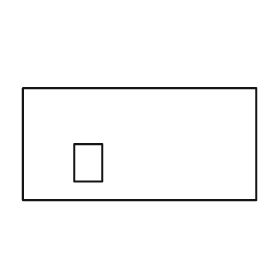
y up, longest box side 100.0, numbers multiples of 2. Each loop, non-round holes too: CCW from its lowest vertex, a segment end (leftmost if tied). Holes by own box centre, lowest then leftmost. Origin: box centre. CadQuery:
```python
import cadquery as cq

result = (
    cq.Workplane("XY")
    .moveTo(-50.0, -24.0)
    .lineTo(50.0, -24.0)
    .lineTo(50.0, 24.0)
    .lineTo(-50.0, 24.0)
    .close()
    .moveTo(-28.0, -16.0)
    .lineTo(-16.0, -16.0)
    .lineTo(-16.0, 0.0)
    .lineTo(-28.0, 0.0)
    .close()
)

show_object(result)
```